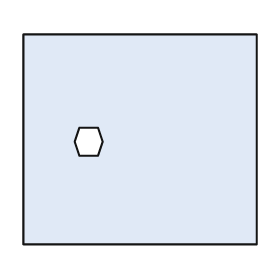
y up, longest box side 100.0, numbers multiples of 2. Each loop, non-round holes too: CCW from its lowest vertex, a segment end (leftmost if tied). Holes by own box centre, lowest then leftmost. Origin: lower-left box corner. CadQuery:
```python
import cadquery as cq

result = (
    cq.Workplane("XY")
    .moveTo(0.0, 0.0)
    .lineTo(100.0, 0.0)
    .lineTo(100.0, 90.0)
    .lineTo(0.0, 90.0)
    .close()
    .moveTo(24.0, 38.0)
    .lineTo(32.0, 38.0)
    .lineTo(34.0, 44.0)
    .lineTo(32.0, 50.0)
    .lineTo(24.0, 50.0)
    .lineTo(22.0, 44.0)
    .close()
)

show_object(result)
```